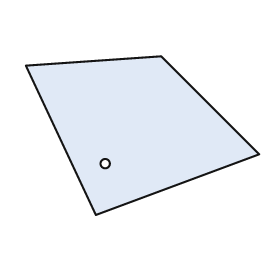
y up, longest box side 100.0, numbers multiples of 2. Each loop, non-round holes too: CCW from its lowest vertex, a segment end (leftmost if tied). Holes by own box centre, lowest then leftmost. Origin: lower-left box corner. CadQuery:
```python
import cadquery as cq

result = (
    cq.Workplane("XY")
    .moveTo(30.0, 0.0)
    .lineTo(100.0, 26.0)
    .lineTo(58.0, 68.0)
    .lineTo(0.0, 64.0)
    .close()
    .moveTo(34.0, 22.0)
    .circle(2.0)
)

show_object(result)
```